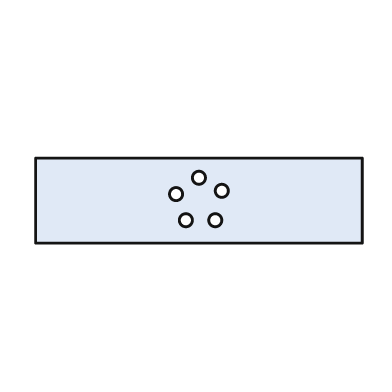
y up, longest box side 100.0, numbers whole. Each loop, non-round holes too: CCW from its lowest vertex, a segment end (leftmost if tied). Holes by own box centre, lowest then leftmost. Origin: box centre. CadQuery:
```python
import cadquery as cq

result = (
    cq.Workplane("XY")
    .moveTo(-50.0, -13.0)
    .lineTo(50.0, -13.0)
    .lineTo(50.0, 13.0)
    .lineTo(-50.0, 13.0)
    .close()
    .moveTo(-4.0, -6.0)
    .circle(2.0)
    .moveTo(5.0, -6.0)
    .circle(2.0)
    .moveTo(-7.0, 2.0)
    .circle(2.0)
    .moveTo(7.0, 3.0)
    .circle(2.0)
    .moveTo(0.0, 7.0)
    .circle(2.0)
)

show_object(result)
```